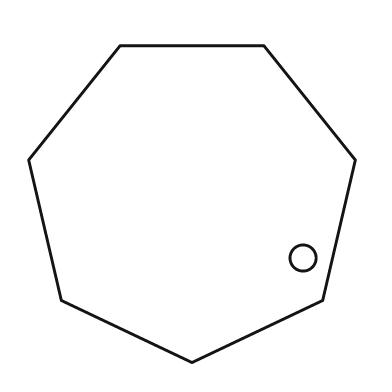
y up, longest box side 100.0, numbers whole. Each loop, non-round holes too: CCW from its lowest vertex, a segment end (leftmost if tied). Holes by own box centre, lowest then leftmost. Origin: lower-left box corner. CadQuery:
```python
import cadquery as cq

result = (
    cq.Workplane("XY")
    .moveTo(50.0, 0.0)
    .lineTo(90.0, 19.0)
    .lineTo(100.0, 62.0)
    .lineTo(72.0, 97.0)
    .lineTo(28.0, 97.0)
    .lineTo(0.0, 62.0)
    .lineTo(10.0, 19.0)
    .close()
    .moveTo(84.0, 32.0)
    .circle(4.0)
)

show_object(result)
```